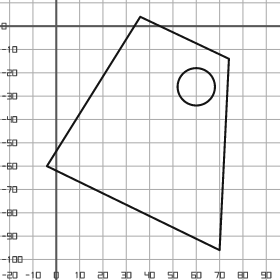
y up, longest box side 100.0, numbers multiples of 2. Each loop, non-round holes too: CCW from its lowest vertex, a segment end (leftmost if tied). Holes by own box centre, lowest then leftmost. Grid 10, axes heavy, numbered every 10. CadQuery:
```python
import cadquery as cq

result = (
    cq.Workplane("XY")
    .moveTo(70.0, -96.0)
    .lineTo(74.0, -14.0)
    .lineTo(36.0, 4.0)
    .lineTo(-4.0, -60.0)
    .close()
    .moveTo(60.0, -26.0)
    .circle(8.0)
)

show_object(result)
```